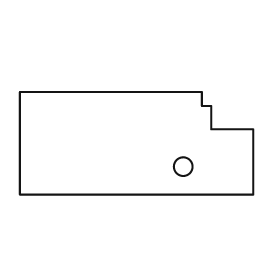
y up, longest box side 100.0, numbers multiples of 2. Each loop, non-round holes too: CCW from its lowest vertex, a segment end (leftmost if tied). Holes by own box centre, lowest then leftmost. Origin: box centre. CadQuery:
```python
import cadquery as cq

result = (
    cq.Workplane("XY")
    .moveTo(-50.0, -22.0)
    .lineTo(50.0, -22.0)
    .lineTo(50.0, 6.0)
    .lineTo(32.0, 6.0)
    .lineTo(32.0, 16.0)
    .lineTo(28.0, 16.0)
    .lineTo(28.0, 22.0)
    .lineTo(-50.0, 22.0)
    .close()
    .moveTo(20.0, -10.0)
    .circle(4.0)
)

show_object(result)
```